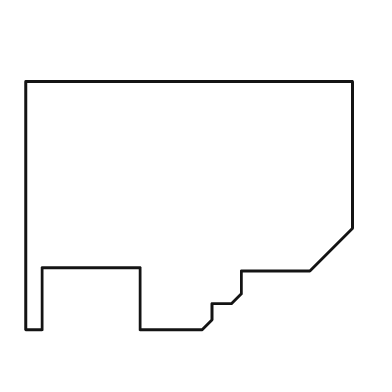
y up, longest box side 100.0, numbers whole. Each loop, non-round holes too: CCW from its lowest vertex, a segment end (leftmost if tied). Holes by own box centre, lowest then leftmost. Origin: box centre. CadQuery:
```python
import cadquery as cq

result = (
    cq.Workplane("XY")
    .moveTo(-50.0, -38.0)
    .lineTo(-45.0, -38.0)
    .lineTo(-45.0, -19.0)
    .lineTo(-15.0, -19.0)
    .lineTo(-15.0, -38.0)
    .lineTo(4.0, -38.0)
    .lineTo(7.0, -35.0)
    .lineTo(7.0, -30.0)
    .lineTo(13.0, -30.0)
    .lineTo(16.0, -27.0)
    .lineTo(16.0, -20.0)
    .lineTo(37.0, -20.0)
    .lineTo(50.0, -7.0)
    .lineTo(50.0, 38.0)
    .lineTo(-50.0, 38.0)
    .close()
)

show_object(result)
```